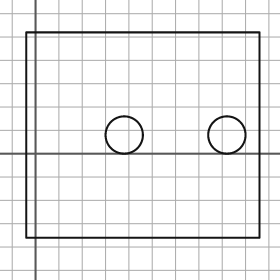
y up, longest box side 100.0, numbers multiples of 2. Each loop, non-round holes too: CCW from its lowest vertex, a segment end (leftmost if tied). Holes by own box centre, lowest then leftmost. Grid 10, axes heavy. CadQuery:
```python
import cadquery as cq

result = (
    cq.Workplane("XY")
    .moveTo(-4.0, -36.0)
    .lineTo(96.0, -36.0)
    .lineTo(96.0, 52.0)
    .lineTo(-4.0, 52.0)
    .close()
    .moveTo(38.0, 8.0)
    .circle(8.0)
    .moveTo(82.0, 8.0)
    .circle(8.0)
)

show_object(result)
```